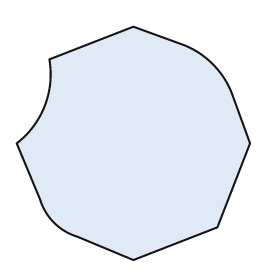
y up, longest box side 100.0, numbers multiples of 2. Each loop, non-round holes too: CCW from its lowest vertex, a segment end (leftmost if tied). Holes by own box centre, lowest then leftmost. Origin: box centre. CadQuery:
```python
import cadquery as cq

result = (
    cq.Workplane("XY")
    .moveTo(0.0, -50.0)
    .lineTo(36.0, -36.0)
    .lineTo(50.0, 0.0)
    .lineTo(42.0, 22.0)
    .threePointArc((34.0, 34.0), (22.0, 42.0))
    .lineTo(0.0, 50.0)
    .lineTo(-36.0, 36.0)
    .threePointArc((-38.0, 16.0), (-50.0, 0.0))
    .lineTo(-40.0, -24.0)
    .threePointArc((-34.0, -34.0), (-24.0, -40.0))
    .close()
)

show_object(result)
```